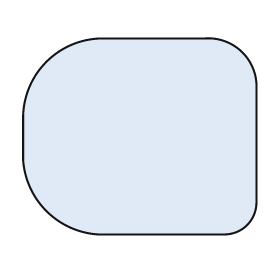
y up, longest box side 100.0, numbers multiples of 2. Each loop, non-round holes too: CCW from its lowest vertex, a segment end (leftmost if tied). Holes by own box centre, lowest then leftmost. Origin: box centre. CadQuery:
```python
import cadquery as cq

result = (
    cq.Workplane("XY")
    .moveTo(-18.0, -42.0)
    .lineTo(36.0, -42.0)
    .threePointArc((46.0, -38.0), (50.0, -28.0))
    .lineTo(50.0, 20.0)
    .threePointArc((44.0, 36.0), (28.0, 42.0))
    .lineTo(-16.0, 42.0)
    .threePointArc((-40.0, 32.0), (-50.0, 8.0))
    .lineTo(-50.0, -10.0)
    .threePointArc((-40.0, -32.0), (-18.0, -42.0))
    .close()
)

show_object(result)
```